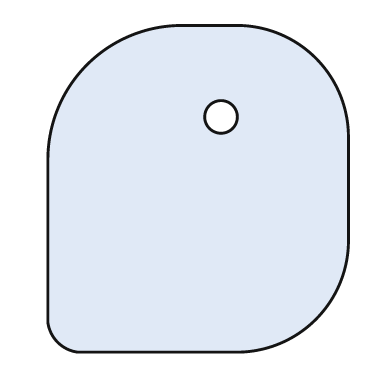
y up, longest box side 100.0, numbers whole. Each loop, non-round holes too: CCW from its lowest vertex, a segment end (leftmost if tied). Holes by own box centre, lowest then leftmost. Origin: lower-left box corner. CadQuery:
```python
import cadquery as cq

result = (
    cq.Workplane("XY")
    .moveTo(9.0, 0.0)
    .lineTo(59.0, 0.0)
    .threePointArc((82.0, 10.0), (92.0, 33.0))
    .lineTo(92.0, 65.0)
    .threePointArc((82.0, 90.0), (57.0, 100.0))
    .lineTo(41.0, 100.0)
    .threePointArc((12.0, 88.0), (0.0, 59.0))
    .lineTo(0.0, 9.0)
    .threePointArc((3.0, 3.0), (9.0, 0.0))
    .close()
    .moveTo(53.0, 72.0)
    .circle(5.0)
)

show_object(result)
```